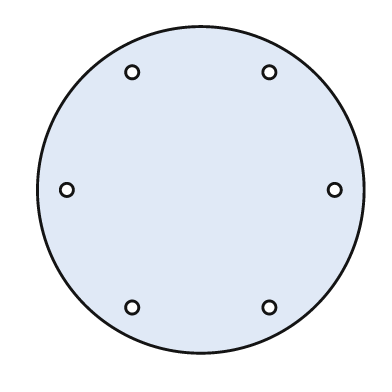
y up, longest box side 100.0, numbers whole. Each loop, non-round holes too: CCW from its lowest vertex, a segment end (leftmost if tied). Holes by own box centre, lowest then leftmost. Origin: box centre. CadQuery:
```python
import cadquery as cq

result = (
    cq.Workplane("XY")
    .moveTo(0.0, 0.0)
    .circle(50.0)
    .moveTo(-21.0, -36.0)
    .circle(2.0)
    .moveTo(21.0, -36.0)
    .circle(2.0)
    .moveTo(-41.0, 0.0)
    .circle(2.0)
    .moveTo(41.0, 0.0)
    .circle(2.0)
    .moveTo(-21.0, 36.0)
    .circle(2.0)
    .moveTo(21.0, 36.0)
    .circle(2.0)
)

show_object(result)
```